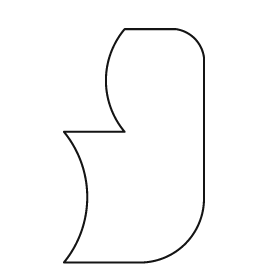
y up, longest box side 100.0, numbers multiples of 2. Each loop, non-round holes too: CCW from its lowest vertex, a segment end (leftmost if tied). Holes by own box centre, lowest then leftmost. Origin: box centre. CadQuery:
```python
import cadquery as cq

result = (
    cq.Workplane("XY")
    .moveTo(-30.0, -50.0)
    .lineTo(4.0, -50.0)
    .threePointArc((22.0, -42.0), (30.0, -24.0))
    .lineTo(30.0, 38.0)
    .threePointArc((26.0, 46.0), (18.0, 50.0))
    .lineTo(-4.0, 50.0)
    .threePointArc((-12.0, 28.0), (-4.0, 6.0))
    .lineTo(-30.0, 6.0)
    .threePointArc((-20.0, -22.0), (-30.0, -50.0))
    .close()
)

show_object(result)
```